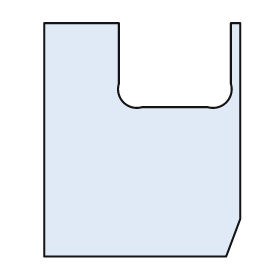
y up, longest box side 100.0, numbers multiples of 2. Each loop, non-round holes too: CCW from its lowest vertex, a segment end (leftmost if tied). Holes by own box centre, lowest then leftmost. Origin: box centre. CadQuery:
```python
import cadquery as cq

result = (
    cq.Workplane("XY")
    .moveTo(-42.0, -50.0)
    .lineTo(36.0, -50.0)
    .lineTo(42.0, -34.0)
    .lineTo(42.0, 50.0)
    .lineTo(38.0, 50.0)
    .lineTo(38.0, 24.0)
    .threePointArc((36.0, 16.0), (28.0, 14.0))
    .lineTo(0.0, 14.0)
    .threePointArc((-8.0, 16.0), (-10.0, 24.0))
    .lineTo(-10.0, 50.0)
    .lineTo(-42.0, 50.0)
    .close()
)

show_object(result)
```